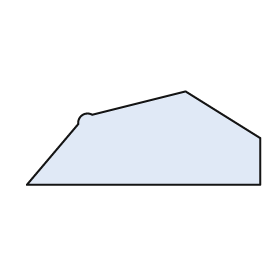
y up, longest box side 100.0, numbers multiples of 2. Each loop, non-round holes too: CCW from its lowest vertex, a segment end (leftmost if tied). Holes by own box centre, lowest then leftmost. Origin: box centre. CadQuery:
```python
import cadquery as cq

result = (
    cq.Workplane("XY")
    .moveTo(-50.0, -20.0)
    .lineTo(50.0, -20.0)
    .lineTo(50.0, 0.0)
    .lineTo(18.0, 20.0)
    .lineTo(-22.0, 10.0)
    .threePointArc((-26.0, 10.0), (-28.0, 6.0))
    .close()
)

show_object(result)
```